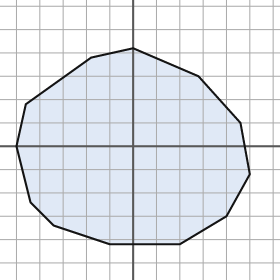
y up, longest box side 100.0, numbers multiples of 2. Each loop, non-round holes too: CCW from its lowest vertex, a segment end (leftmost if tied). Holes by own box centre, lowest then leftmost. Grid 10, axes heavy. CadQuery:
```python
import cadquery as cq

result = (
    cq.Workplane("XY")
    .moveTo(-10.0, -42.0)
    .lineTo(20.0, -42.0)
    .lineTo(40.0, -30.0)
    .lineTo(50.0, -12.0)
    .lineTo(46.0, 10.0)
    .lineTo(28.0, 30.0)
    .lineTo(0.0, 42.0)
    .lineTo(-18.0, 38.0)
    .lineTo(-46.0, 18.0)
    .lineTo(-50.0, 0.0)
    .lineTo(-44.0, -24.0)
    .lineTo(-34.0, -34.0)
    .close()
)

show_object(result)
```